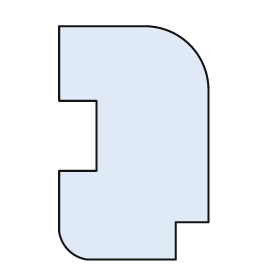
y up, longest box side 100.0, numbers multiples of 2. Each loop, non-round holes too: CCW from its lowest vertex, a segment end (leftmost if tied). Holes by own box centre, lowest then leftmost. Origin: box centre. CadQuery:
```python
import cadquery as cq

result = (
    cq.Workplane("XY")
    .moveTo(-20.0, -50.0)
    .lineTo(18.0, -50.0)
    .lineTo(18.0, -34.0)
    .lineTo(32.0, -34.0)
    .lineTo(32.0, 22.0)
    .threePointArc((24.0, 42.0), (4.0, 50.0))
    .lineTo(-32.0, 50.0)
    .lineTo(-32.0, 18.0)
    .lineTo(-16.0, 18.0)
    .lineTo(-16.0, -12.0)
    .lineTo(-32.0, -12.0)
    .lineTo(-32.0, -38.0)
    .threePointArc((-28.0, -46.0), (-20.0, -50.0))
    .close()
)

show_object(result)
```